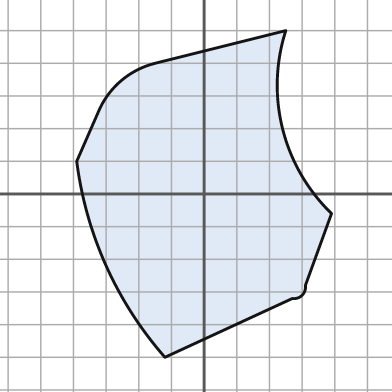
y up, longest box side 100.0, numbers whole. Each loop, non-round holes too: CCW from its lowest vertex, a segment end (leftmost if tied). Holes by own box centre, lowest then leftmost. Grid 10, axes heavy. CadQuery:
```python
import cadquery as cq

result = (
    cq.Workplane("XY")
    .moveTo(-12.0, -50.0)
    .lineTo(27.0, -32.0)
    .threePointArc((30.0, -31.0), (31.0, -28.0))
    .lineTo(39.0, -6.0)
    .threePointArc((24.0, 20.0), (25.0, 50.0))
    .lineTo(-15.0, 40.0)
    .threePointArc((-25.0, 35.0), (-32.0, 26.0))
    .lineTo(-39.0, 10.0)
    .threePointArc((-30.0, -22.0), (-12.0, -50.0))
    .close()
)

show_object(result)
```